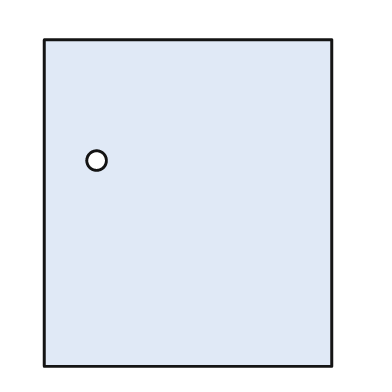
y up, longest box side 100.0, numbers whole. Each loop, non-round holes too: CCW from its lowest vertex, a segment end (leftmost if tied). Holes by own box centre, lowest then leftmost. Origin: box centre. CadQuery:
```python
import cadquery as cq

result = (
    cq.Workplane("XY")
    .moveTo(-44.0, -50.0)
    .lineTo(44.0, -50.0)
    .lineTo(44.0, 50.0)
    .lineTo(-44.0, 50.0)
    .close()
    .moveTo(-28.0, 13.0)
    .circle(3.0)
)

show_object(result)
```